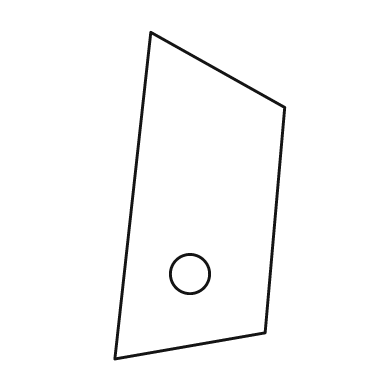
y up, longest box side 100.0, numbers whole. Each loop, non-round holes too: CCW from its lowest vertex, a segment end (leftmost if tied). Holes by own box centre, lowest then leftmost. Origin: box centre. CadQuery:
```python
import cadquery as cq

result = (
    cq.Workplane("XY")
    .moveTo(-26.0, -50.0)
    .lineTo(20.0, -42.0)
    .lineTo(26.0, 27.0)
    .lineTo(-15.0, 50.0)
    .close()
    .moveTo(-3.0, -24.0)
    .circle(6.0)
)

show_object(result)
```